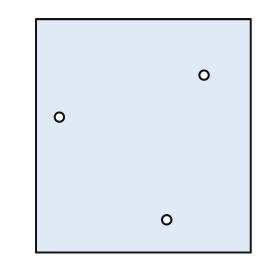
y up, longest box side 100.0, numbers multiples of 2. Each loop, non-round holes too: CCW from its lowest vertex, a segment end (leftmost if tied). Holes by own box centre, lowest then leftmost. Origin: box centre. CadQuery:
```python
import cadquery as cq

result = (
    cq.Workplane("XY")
    .moveTo(-46.0, -50.0)
    .lineTo(46.0, -50.0)
    .lineTo(46.0, 50.0)
    .lineTo(-46.0, 50.0)
    .close()
    .moveTo(10.0, -36.0)
    .circle(2.0)
    .moveTo(-36.0, 8.0)
    .circle(2.0)
    .moveTo(26.0, 26.0)
    .circle(2.0)
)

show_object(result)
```